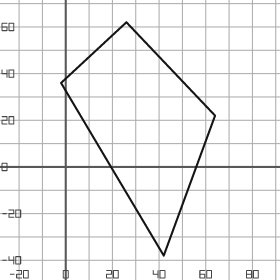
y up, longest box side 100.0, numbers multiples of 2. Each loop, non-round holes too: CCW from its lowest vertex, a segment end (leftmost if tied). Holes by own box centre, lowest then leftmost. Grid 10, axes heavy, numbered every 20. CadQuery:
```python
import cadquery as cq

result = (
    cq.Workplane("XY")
    .moveTo(42.0, -38.0)
    .lineTo(64.0, 22.0)
    .lineTo(26.0, 62.0)
    .lineTo(-2.0, 36.0)
    .close()
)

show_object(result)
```